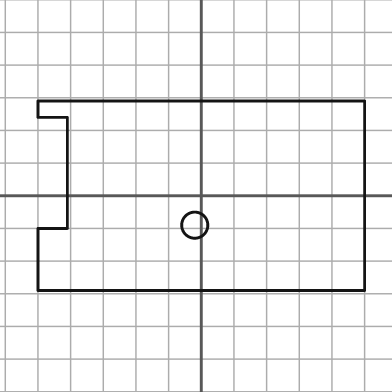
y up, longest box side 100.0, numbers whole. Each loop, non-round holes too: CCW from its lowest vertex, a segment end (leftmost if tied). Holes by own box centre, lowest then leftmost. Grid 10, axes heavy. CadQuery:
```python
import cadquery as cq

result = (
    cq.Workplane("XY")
    .moveTo(-50.0, -29.0)
    .lineTo(50.0, -29.0)
    .lineTo(50.0, 29.0)
    .lineTo(-50.0, 29.0)
    .lineTo(-50.0, 24.0)
    .lineTo(-41.0, 24.0)
    .lineTo(-41.0, -10.0)
    .lineTo(-50.0, -10.0)
    .close()
    .moveTo(-2.0, -9.0)
    .circle(4.0)
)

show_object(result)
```